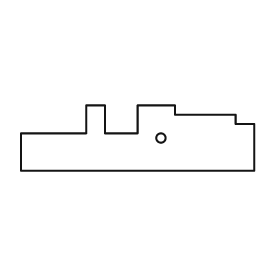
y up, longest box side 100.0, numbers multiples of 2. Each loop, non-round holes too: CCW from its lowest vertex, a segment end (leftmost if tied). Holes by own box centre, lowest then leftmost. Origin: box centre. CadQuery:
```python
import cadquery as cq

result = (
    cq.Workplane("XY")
    .moveTo(-50.0, -14.0)
    .lineTo(50.0, -14.0)
    .lineTo(50.0, 6.0)
    .lineTo(42.0, 6.0)
    .lineTo(42.0, 10.0)
    .lineTo(16.0, 10.0)
    .lineTo(16.0, 14.0)
    .lineTo(0.0, 14.0)
    .lineTo(0.0, 2.0)
    .lineTo(-14.0, 2.0)
    .lineTo(-14.0, 14.0)
    .lineTo(-22.0, 14.0)
    .lineTo(-22.0, 2.0)
    .lineTo(-50.0, 2.0)
    .close()
    .moveTo(10.0, 0.0)
    .circle(2.0)
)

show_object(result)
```